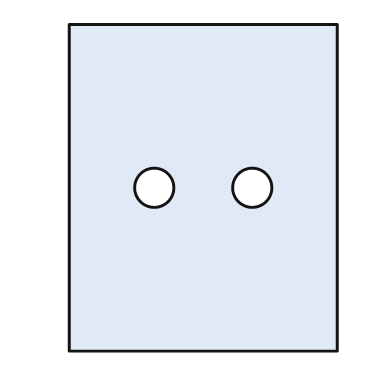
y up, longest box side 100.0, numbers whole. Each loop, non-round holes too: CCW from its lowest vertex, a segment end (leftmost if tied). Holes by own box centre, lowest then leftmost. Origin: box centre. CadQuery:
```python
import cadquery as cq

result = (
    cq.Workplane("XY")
    .moveTo(-41.0, -50.0)
    .lineTo(41.0, -50.0)
    .lineTo(41.0, 50.0)
    .lineTo(-41.0, 50.0)
    .close()
    .moveTo(-15.0, 0.0)
    .circle(6.0)
    .moveTo(15.0, 0.0)
    .circle(6.0)
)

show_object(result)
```